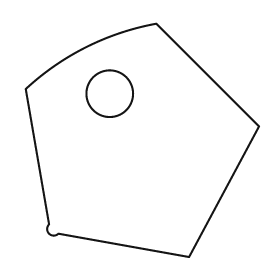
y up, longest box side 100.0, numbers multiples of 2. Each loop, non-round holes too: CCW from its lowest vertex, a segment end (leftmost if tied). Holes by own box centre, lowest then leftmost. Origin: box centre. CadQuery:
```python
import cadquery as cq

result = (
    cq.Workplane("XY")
    .moveTo(20.0, -50.0)
    .lineTo(50.0, 6.0)
    .lineTo(6.0, 50.0)
    .threePointArc((-24.0, 40.0), (-50.0, 22.0))
    .lineTo(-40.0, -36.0)
    .threePointArc((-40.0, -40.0), (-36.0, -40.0))
    .close()
    .moveTo(-14.0, 20.0)
    .circle(10.0)
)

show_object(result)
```